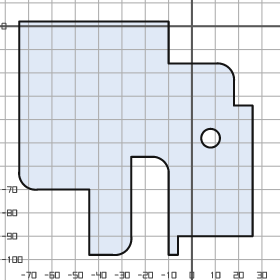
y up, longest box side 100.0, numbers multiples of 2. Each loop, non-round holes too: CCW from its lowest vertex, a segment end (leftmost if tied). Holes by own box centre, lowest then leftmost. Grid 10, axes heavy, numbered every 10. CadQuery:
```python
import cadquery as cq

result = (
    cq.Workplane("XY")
    .moveTo(-44.0, -98.0)
    .lineTo(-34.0, -98.0)
    .threePointArc((-28.0, -96.0), (-26.0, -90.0))
    .lineTo(-26.0, -56.0)
    .lineTo(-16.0, -56.0)
    .threePointArc((-12.0, -58.0), (-10.0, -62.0))
    .lineTo(-10.0, -98.0)
    .lineTo(-6.0, -98.0)
    .lineTo(-6.0, -90.0)
    .lineTo(26.0, -90.0)
    .lineTo(26.0, -34.0)
    .lineTo(18.0, -34.0)
    .lineTo(18.0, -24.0)
    .threePointArc((16.0, -18.0), (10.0, -16.0))
    .lineTo(-10.0, -16.0)
    .lineTo(-10.0, 2.0)
    .lineTo(-74.0, 2.0)
    .lineTo(-74.0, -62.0)
    .threePointArc((-72.0, -68.0), (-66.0, -70.0))
    .lineTo(-44.0, -70.0)
    .close()
    .moveTo(8.0, -48.0)
    .circle(4.0)
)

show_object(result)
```